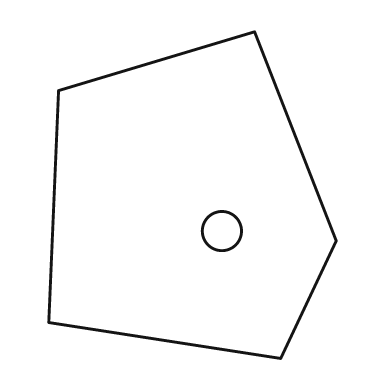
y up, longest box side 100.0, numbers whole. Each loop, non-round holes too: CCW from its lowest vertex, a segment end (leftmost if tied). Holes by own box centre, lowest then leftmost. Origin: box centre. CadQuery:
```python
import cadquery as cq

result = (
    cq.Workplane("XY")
    .moveTo(27.0, -50.0)
    .lineTo(44.0, -14.0)
    .lineTo(19.0, 50.0)
    .lineTo(-41.0, 32.0)
    .lineTo(-44.0, -39.0)
    .close()
    .moveTo(9.0, -11.0)
    .circle(6.0)
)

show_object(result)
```